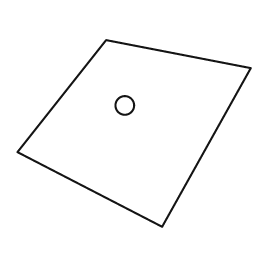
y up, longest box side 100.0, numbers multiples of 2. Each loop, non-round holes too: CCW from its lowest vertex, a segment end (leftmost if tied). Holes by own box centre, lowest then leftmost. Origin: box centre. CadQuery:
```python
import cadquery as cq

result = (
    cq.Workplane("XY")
    .moveTo(12.0, -40.0)
    .lineTo(50.0, 28.0)
    .lineTo(-12.0, 40.0)
    .lineTo(-50.0, -8.0)
    .close()
    .moveTo(-4.0, 12.0)
    .circle(4.0)
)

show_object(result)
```